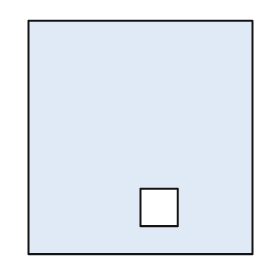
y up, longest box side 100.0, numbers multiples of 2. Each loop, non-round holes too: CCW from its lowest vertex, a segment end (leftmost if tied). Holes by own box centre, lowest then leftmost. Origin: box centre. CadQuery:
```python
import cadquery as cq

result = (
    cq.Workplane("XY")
    .moveTo(-48.0, -50.0)
    .lineTo(48.0, -50.0)
    .lineTo(48.0, 50.0)
    .lineTo(-48.0, 50.0)
    .close()
    .moveTo(0.0, -38.0)
    .lineTo(16.0, -38.0)
    .lineTo(16.0, -22.0)
    .lineTo(0.0, -22.0)
    .close()
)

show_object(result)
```